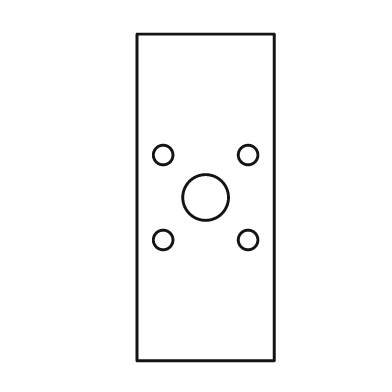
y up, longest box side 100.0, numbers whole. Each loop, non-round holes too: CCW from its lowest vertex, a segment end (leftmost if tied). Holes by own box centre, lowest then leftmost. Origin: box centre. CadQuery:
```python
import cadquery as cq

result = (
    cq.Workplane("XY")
    .moveTo(-21.0, -50.0)
    .lineTo(21.0, -50.0)
    .lineTo(21.0, 50.0)
    .lineTo(-21.0, 50.0)
    .close()
    .moveTo(-13.0, -13.0)
    .circle(3.0)
    .moveTo(13.0, -13.0)
    .circle(3.0)
    .moveTo(0.0, 0.0)
    .circle(7.0)
    .moveTo(-13.0, 13.0)
    .circle(3.0)
    .moveTo(13.0, 13.0)
    .circle(3.0)
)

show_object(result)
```